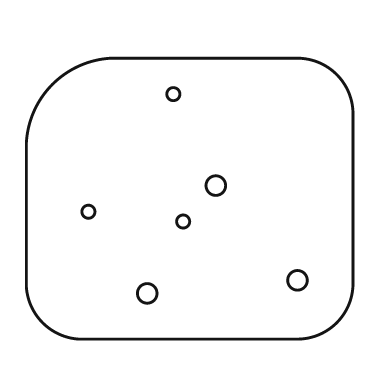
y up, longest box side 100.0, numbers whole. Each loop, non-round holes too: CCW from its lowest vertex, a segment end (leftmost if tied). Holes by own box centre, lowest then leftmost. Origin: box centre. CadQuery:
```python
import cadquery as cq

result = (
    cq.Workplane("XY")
    .moveTo(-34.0, -43.0)
    .lineTo(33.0, -43.0)
    .threePointArc((45.0, -38.0), (50.0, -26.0))
    .lineTo(50.0, 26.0)
    .threePointArc((45.0, 38.0), (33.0, 43.0))
    .lineTo(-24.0, 43.0)
    .threePointArc((-42.0, 35.0), (-50.0, 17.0))
    .lineTo(-50.0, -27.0)
    .threePointArc((-45.0, -38.0), (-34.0, -43.0))
    .close()
    .moveTo(-13.0, -29.0)
    .circle(3.0)
    .moveTo(33.0, -25.0)
    .circle(3.0)
    .moveTo(-2.0, -7.0)
    .circle(2.0)
    .moveTo(-31.0, -4.0)
    .circle(2.0)
    .moveTo(8.0, 4.0)
    .circle(3.0)
    .moveTo(-5.0, 32.0)
    .circle(2.0)
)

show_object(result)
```